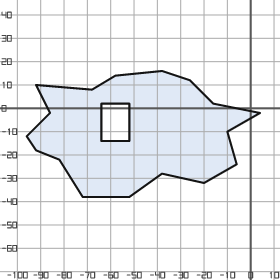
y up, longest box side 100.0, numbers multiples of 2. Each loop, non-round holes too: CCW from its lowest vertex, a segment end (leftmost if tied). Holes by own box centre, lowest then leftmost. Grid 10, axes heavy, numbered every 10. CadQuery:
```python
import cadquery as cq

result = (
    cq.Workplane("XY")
    .moveTo(-72.0, -38.0)
    .lineTo(-52.0, -38.0)
    .lineTo(-38.0, -28.0)
    .lineTo(-20.0, -32.0)
    .lineTo(-6.0, -24.0)
    .lineTo(-10.0, -10.0)
    .lineTo(4.0, -2.0)
    .lineTo(-16.0, 2.0)
    .lineTo(-26.0, 12.0)
    .lineTo(-38.0, 16.0)
    .lineTo(-58.0, 14.0)
    .lineTo(-68.0, 8.0)
    .lineTo(-92.0, 10.0)
    .lineTo(-86.0, -2.0)
    .lineTo(-96.0, -12.0)
    .lineTo(-92.0, -18.0)
    .lineTo(-82.0, -22.0)
    .close()
    .moveTo(-64.0, -14.0)
    .lineTo(-52.0, -14.0)
    .lineTo(-52.0, 2.0)
    .lineTo(-64.0, 2.0)
    .close()
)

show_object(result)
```